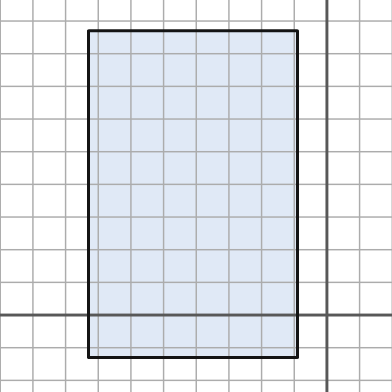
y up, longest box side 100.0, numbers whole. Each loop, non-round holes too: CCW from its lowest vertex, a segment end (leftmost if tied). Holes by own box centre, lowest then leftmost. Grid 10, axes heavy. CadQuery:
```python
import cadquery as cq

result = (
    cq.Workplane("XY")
    .moveTo(-73.0, -13.0)
    .lineTo(-9.0, -13.0)
    .lineTo(-9.0, 87.0)
    .lineTo(-73.0, 87.0)
    .close()
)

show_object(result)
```